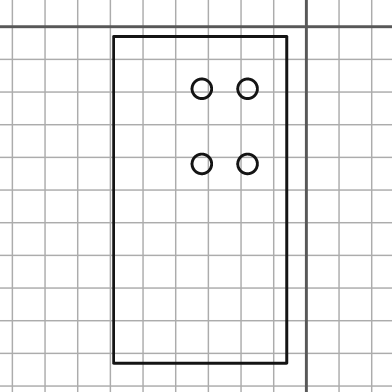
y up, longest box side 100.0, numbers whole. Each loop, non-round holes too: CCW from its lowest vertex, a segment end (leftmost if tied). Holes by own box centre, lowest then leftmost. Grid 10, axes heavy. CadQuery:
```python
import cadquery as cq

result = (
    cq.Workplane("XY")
    .moveTo(-59.0, -103.0)
    .lineTo(-6.0, -103.0)
    .lineTo(-6.0, -3.0)
    .lineTo(-59.0, -3.0)
    .close()
    .moveTo(-32.0, -42.0)
    .circle(3.0)
    .moveTo(-18.0, -42.0)
    .circle(3.0)
    .moveTo(-32.0, -19.0)
    .circle(3.0)
    .moveTo(-18.0, -19.0)
    .circle(3.0)
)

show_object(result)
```